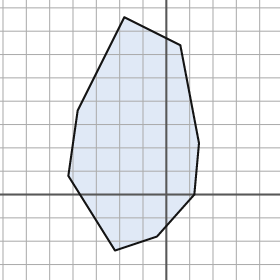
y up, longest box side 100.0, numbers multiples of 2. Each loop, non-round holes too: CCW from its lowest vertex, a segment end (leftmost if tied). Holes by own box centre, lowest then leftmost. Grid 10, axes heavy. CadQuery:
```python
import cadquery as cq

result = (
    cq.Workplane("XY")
    .moveTo(-22.0, -24.0)
    .lineTo(-4.0, -18.0)
    .lineTo(12.0, 0.0)
    .lineTo(14.0, 22.0)
    .lineTo(6.0, 64.0)
    .lineTo(-18.0, 76.0)
    .lineTo(-38.0, 36.0)
    .lineTo(-42.0, 8.0)
    .close()
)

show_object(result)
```